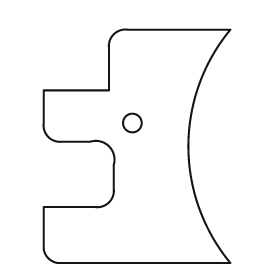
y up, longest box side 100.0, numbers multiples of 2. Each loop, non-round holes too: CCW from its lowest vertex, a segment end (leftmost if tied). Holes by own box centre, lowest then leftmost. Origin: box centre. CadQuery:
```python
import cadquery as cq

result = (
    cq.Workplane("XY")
    .moveTo(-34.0, -50.0)
    .lineTo(40.0, -50.0)
    .threePointArc((22.0, 0.0), (40.0, 50.0))
    .lineTo(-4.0, 50.0)
    .threePointArc((-10.0, 48.0), (-12.0, 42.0))
    .lineTo(-12.0, 24.0)
    .lineTo(-40.0, 24.0)
    .lineTo(-40.0, 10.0)
    .threePointArc((-38.0, 4.0), (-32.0, 2.0))
    .lineTo(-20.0, 2.0)
    .threePointArc((-12.0, 0.0), (-10.0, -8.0))
    .lineTo(-10.0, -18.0)
    .threePointArc((-12.0, -24.0), (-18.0, -26.0))
    .lineTo(-40.0, -26.0)
    .lineTo(-40.0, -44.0)
    .threePointArc((-38.0, -48.0), (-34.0, -50.0))
    .close()
    .moveTo(-2.0, 10.0)
    .circle(4.0)
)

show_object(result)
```